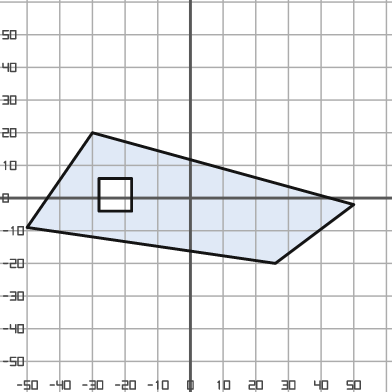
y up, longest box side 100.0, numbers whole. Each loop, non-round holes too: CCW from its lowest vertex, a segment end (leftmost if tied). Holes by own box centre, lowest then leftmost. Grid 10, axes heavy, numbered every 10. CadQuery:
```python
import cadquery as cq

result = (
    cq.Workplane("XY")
    .moveTo(26.0, -20.0)
    .lineTo(50.0, -2.0)
    .lineTo(-30.0, 20.0)
    .lineTo(-50.0, -9.0)
    .close()
    .moveTo(-28.0, -4.0)
    .lineTo(-18.0, -4.0)
    .lineTo(-18.0, 6.0)
    .lineTo(-28.0, 6.0)
    .close()
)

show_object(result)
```